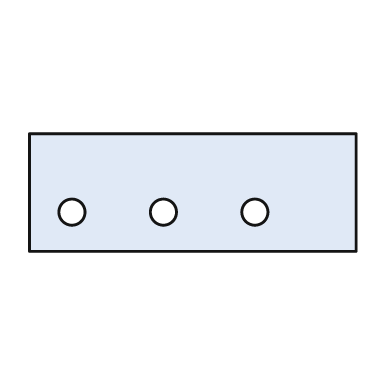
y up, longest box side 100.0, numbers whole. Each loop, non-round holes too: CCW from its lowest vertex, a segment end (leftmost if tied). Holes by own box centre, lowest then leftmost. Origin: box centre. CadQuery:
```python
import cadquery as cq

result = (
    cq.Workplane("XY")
    .moveTo(-50.0, -18.0)
    .lineTo(50.0, -18.0)
    .lineTo(50.0, 18.0)
    .lineTo(-50.0, 18.0)
    .close()
    .moveTo(-37.0, -6.0)
    .circle(4.0)
    .moveTo(-9.0, -6.0)
    .circle(4.0)
    .moveTo(19.0, -6.0)
    .circle(4.0)
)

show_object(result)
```